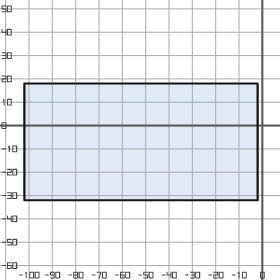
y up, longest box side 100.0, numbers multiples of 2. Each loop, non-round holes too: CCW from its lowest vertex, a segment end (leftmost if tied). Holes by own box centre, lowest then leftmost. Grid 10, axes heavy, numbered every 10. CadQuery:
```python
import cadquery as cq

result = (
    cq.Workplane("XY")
    .moveTo(-102.0, -32.0)
    .lineTo(-2.0, -32.0)
    .lineTo(-2.0, 18.0)
    .lineTo(-102.0, 18.0)
    .close()
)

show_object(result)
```